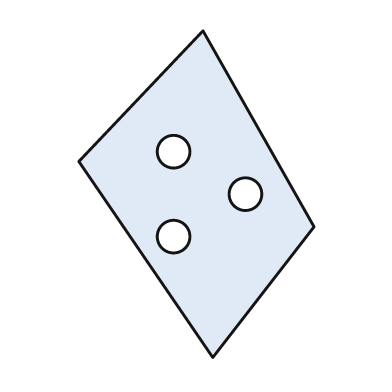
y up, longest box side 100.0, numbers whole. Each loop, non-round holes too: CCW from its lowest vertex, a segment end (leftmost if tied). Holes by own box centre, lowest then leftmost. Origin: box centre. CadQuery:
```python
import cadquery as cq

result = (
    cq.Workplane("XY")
    .moveTo(5.0, -50.0)
    .lineTo(36.0, -10.0)
    .lineTo(2.0, 50.0)
    .lineTo(-36.0, 10.0)
    .close()
    .moveTo(-7.0, -13.0)
    .circle(5.0)
    .moveTo(15.0, 0.0)
    .circle(5.0)
    .moveTo(-7.0, 13.0)
    .circle(5.0)
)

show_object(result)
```